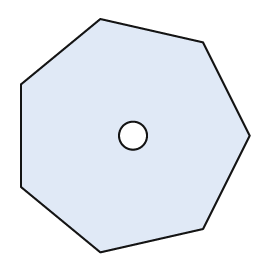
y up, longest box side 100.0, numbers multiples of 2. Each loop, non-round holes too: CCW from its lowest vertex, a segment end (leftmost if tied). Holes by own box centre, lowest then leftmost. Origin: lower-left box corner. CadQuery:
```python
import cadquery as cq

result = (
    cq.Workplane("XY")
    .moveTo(34.0, 0.0)
    .lineTo(78.0, 10.0)
    .lineTo(98.0, 50.0)
    .lineTo(78.0, 90.0)
    .lineTo(34.0, 100.0)
    .lineTo(0.0, 72.0)
    .lineTo(0.0, 28.0)
    .close()
    .moveTo(48.0, 50.0)
    .circle(6.0)
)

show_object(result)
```